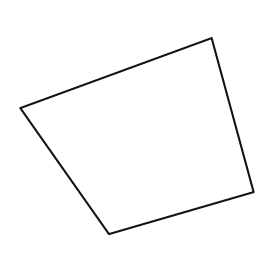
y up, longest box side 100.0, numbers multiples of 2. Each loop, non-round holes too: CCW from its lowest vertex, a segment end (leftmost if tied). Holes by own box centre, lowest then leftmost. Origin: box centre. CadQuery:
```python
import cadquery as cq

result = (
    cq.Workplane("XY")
    .moveTo(-12.0, -42.0)
    .lineTo(50.0, -24.0)
    .lineTo(32.0, 42.0)
    .lineTo(-50.0, 12.0)
    .close()
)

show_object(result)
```